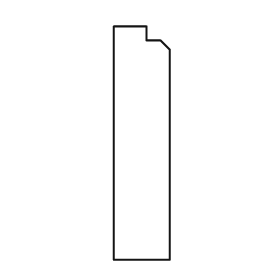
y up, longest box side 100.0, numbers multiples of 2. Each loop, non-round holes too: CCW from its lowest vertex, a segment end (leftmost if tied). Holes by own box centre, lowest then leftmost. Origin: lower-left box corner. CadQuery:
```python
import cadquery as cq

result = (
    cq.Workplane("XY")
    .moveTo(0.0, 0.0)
    .lineTo(24.0, 0.0)
    .lineTo(24.0, 90.0)
    .lineTo(20.0, 94.0)
    .lineTo(14.0, 94.0)
    .lineTo(14.0, 100.0)
    .lineTo(0.0, 100.0)
    .close()
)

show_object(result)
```